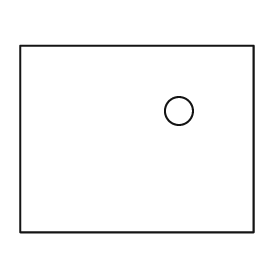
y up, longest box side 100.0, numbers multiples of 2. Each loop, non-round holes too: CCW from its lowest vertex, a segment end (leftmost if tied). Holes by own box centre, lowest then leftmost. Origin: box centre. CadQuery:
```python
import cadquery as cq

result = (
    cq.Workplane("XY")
    .moveTo(-50.0, -40.0)
    .lineTo(50.0, -40.0)
    .lineTo(50.0, 40.0)
    .lineTo(-50.0, 40.0)
    .close()
    .moveTo(18.0, 12.0)
    .circle(6.0)
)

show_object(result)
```